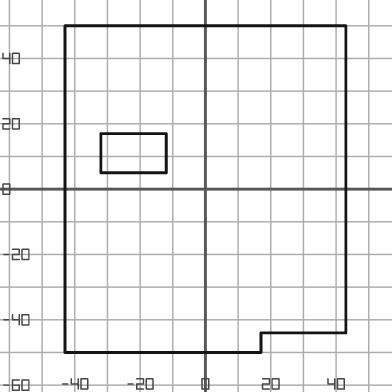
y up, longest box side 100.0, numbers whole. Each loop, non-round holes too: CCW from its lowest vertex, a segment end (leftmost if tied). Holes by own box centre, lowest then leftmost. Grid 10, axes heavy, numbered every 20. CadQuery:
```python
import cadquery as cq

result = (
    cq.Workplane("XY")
    .moveTo(-43.0, -50.0)
    .lineTo(17.0, -50.0)
    .lineTo(17.0, -44.0)
    .lineTo(43.0, -44.0)
    .lineTo(43.0, 50.0)
    .lineTo(-43.0, 50.0)
    .close()
    .moveTo(-32.0, 5.0)
    .lineTo(-12.0, 5.0)
    .lineTo(-12.0, 17.0)
    .lineTo(-32.0, 17.0)
    .close()
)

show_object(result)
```